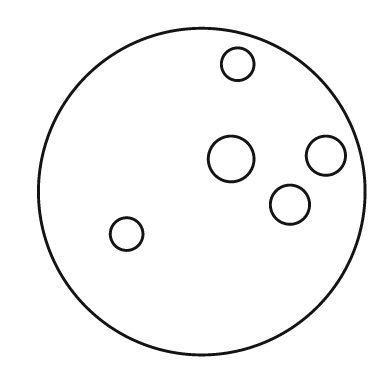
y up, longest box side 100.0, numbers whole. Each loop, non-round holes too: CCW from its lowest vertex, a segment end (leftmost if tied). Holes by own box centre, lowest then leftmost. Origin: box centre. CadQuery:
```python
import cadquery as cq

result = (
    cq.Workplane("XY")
    .moveTo(0.0, 0.0)
    .circle(50.0)
    .moveTo(-23.0, -13.0)
    .circle(5.0)
    .moveTo(27.0, -4.0)
    .circle(6.0)
    .moveTo(9.0, 10.0)
    .circle(7.0)
    .moveTo(38.0, 11.0)
    .circle(6.0)
    .moveTo(11.0, 39.0)
    .circle(5.0)
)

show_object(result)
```